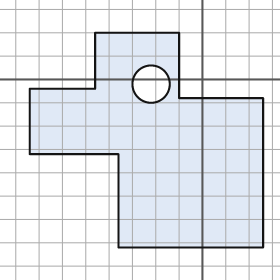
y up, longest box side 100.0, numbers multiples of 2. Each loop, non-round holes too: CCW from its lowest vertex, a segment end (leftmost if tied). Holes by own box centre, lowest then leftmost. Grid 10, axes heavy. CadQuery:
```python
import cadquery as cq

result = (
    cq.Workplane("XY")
    .moveTo(-36.0, -72.0)
    .lineTo(26.0, -72.0)
    .lineTo(26.0, -8.0)
    .lineTo(-10.0, -8.0)
    .lineTo(-10.0, 20.0)
    .lineTo(-46.0, 20.0)
    .lineTo(-46.0, -4.0)
    .lineTo(-74.0, -4.0)
    .lineTo(-74.0, -32.0)
    .lineTo(-36.0, -32.0)
    .close()
    .moveTo(-22.0, -2.0)
    .circle(8.0)
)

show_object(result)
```